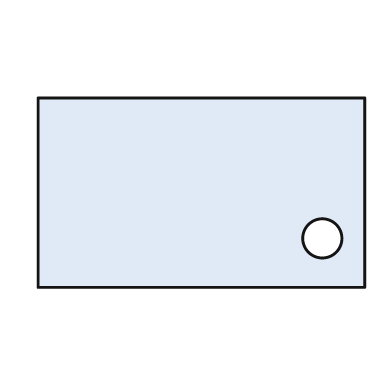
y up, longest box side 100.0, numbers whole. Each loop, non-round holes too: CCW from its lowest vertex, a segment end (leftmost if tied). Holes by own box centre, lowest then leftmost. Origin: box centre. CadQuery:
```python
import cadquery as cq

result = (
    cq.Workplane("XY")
    .moveTo(-50.0, -29.0)
    .lineTo(50.0, -29.0)
    .lineTo(50.0, 29.0)
    .lineTo(-50.0, 29.0)
    .close()
    .moveTo(37.0, -14.0)
    .circle(6.0)
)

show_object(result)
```